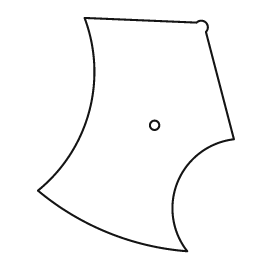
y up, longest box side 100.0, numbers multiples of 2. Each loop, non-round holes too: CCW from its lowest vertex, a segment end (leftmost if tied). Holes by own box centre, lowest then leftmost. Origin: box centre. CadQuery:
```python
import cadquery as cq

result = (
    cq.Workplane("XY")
    .moveTo(22.0, -50.0)
    .threePointArc((18.0, -20.0), (42.0, -2.0))
    .lineTo(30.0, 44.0)
    .threePointArc((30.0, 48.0), (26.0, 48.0))
    .lineTo(-22.0, 50.0)
    .threePointArc((-20.0, 10.0), (-42.0, -24.0))
    .threePointArc((-12.0, -42.0), (22.0, -50.0))
    .close()
    .moveTo(8.0, 4.0)
    .circle(2.0)
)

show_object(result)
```